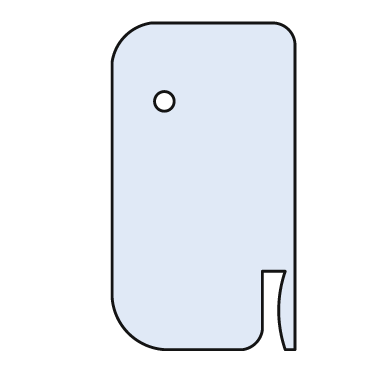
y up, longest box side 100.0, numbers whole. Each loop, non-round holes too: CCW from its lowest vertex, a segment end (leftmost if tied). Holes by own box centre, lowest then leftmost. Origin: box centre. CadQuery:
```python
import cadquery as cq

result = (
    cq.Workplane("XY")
    .moveTo(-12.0, -50.0)
    .lineTo(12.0, -50.0)
    .threePointArc((16.0, -48.0), (18.0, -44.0))
    .lineTo(18.0, -26.0)
    .lineTo(25.0, -26.0)
    .threePointArc((23.0, -38.0), (25.0, -50.0))
    .lineTo(28.0, -50.0)
    .lineTo(28.0, 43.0)
    .threePointArc((26.0, 48.0), (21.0, 50.0))
    .lineTo(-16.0, 50.0)
    .threePointArc((-24.0, 46.0), (-28.0, 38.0))
    .lineTo(-28.0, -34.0)
    .threePointArc((-23.0, -45.0), (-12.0, -50.0))
    .close()
    .moveTo(-12.0, 26.0)
    .circle(3.0)
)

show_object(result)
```